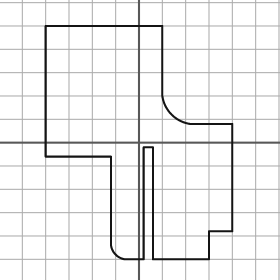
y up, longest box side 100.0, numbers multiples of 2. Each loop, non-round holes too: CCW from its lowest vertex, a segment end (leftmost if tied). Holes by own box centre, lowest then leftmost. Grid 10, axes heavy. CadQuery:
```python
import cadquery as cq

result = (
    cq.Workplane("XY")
    .moveTo(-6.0, -50.0)
    .lineTo(2.0, -50.0)
    .lineTo(2.0, -2.0)
    .lineTo(6.0, -2.0)
    .lineTo(6.0, -50.0)
    .lineTo(30.0, -50.0)
    .lineTo(30.0, -38.0)
    .lineTo(40.0, -38.0)
    .lineTo(40.0, 8.0)
    .lineTo(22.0, 8.0)
    .threePointArc((14.0, 12.0), (10.0, 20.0))
    .lineTo(10.0, 50.0)
    .lineTo(-40.0, 50.0)
    .lineTo(-40.0, -6.0)
    .lineTo(-12.0, -6.0)
    .lineTo(-12.0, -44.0)
    .threePointArc((-10.0, -48.0), (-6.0, -50.0))
    .close()
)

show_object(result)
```